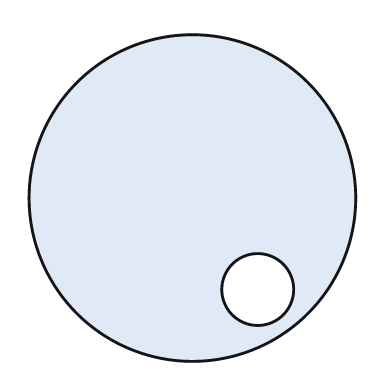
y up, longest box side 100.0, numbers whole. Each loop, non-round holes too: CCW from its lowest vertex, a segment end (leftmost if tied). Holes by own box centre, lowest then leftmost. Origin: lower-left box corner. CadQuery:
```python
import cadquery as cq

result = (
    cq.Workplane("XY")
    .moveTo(50.0, 50.0)
    .circle(50.0)
    .moveTo(70.0, 22.0)
    .circle(11.0)
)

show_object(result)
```